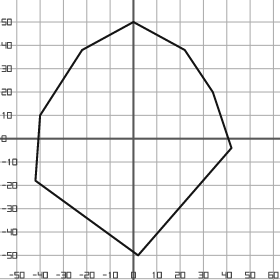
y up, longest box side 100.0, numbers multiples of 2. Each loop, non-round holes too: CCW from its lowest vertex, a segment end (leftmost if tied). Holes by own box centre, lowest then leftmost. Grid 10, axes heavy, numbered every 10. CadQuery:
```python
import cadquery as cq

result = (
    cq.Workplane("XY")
    .moveTo(2.0, -50.0)
    .lineTo(42.0, -4.0)
    .lineTo(34.0, 20.0)
    .lineTo(22.0, 38.0)
    .lineTo(0.0, 50.0)
    .lineTo(-22.0, 38.0)
    .lineTo(-40.0, 10.0)
    .lineTo(-42.0, -18.0)
    .close()
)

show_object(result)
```